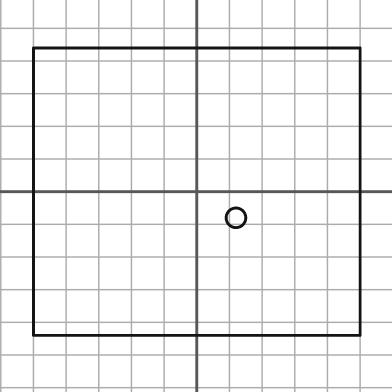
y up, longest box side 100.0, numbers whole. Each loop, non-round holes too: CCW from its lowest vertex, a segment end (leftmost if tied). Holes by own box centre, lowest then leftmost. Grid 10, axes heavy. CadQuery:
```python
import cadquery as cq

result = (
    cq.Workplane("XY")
    .moveTo(-50.0, -44.0)
    .lineTo(50.0, -44.0)
    .lineTo(50.0, 44.0)
    .lineTo(-50.0, 44.0)
    .close()
    .moveTo(12.0, -8.0)
    .circle(3.0)
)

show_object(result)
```